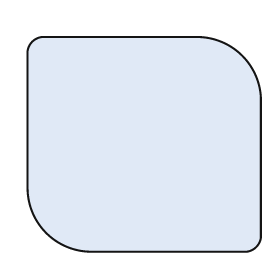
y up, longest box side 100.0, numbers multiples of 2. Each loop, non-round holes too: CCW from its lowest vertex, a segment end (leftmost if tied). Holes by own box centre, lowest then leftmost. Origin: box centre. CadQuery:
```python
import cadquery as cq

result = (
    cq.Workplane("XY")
    .moveTo(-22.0, -46.0)
    .lineTo(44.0, -46.0)
    .threePointArc((48.0, -44.0), (50.0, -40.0))
    .lineTo(50.0, 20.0)
    .threePointArc((42.0, 38.0), (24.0, 46.0))
    .lineTo(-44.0, 46.0)
    .threePointArc((-48.0, 44.0), (-50.0, 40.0))
    .lineTo(-50.0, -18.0)
    .threePointArc((-42.0, -38.0), (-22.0, -46.0))
    .close()
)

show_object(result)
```